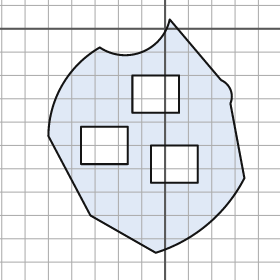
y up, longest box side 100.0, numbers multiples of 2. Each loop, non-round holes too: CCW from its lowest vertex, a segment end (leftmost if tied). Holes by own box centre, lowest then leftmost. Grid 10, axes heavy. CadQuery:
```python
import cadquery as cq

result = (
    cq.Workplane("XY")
    .moveTo(-4.0, -96.0)
    .threePointArc((18.0, -84.0), (34.0, -64.0))
    .lineTo(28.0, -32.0)
    .threePointArc((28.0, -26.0), (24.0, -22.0))
    .lineTo(2.0, 4.0)
    .threePointArc((-10.0, -10.0), (-28.0, -8.0))
    .threePointArc((-44.0, -24.0), (-50.0, -46.0))
    .lineTo(-32.0, -80.0)
    .close()
    .moveTo(-6.0, -66.0)
    .lineTo(14.0, -66.0)
    .lineTo(14.0, -50.0)
    .lineTo(-6.0, -50.0)
    .close()
    .moveTo(-36.0, -58.0)
    .lineTo(-16.0, -58.0)
    .lineTo(-16.0, -42.0)
    .lineTo(-36.0, -42.0)
    .close()
    .moveTo(-14.0, -36.0)
    .lineTo(6.0, -36.0)
    .lineTo(6.0, -20.0)
    .lineTo(-14.0, -20.0)
    .close()
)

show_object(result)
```